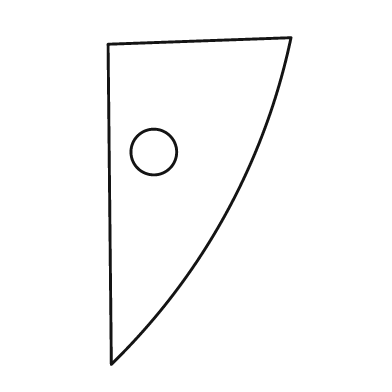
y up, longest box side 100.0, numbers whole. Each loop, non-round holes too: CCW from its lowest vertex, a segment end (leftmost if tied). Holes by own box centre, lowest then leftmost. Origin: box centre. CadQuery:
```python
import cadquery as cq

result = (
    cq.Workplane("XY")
    .moveTo(-27.0, -50.0)
    .threePointArc((8.0, -4.0), (28.0, 50.0))
    .lineTo(-28.0, 48.0)
    .close()
    .moveTo(-14.0, 15.0)
    .circle(7.0)
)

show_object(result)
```